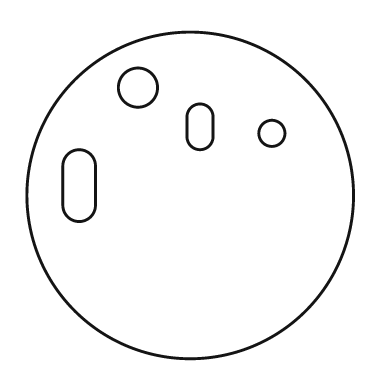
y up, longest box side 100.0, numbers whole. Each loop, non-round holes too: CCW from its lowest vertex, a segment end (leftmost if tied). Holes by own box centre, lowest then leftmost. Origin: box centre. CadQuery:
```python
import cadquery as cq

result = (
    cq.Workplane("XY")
    .moveTo(0.0, 0.0)
    .circle(50.0)
    .moveTo(-39.0, -3.0)
    .threePointArc((-34.0, -8.0), (-29.0, -3.0))
    .lineTo(-29.0, 9.0)
    .threePointArc((-34.0, 14.0), (-39.0, 9.0))
    .close()
    .moveTo(25.0, 19.0)
    .circle(4.0)
    .moveTo(-1.0, 18.0)
    .threePointArc((3.0, 14.0), (7.0, 18.0))
    .lineTo(7.0, 24.0)
    .threePointArc((3.0, 28.0), (-1.0, 24.0))
    .close()
    .moveTo(-16.0, 33.0)
    .circle(6.0)
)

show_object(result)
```